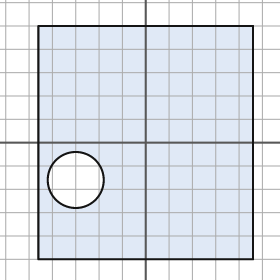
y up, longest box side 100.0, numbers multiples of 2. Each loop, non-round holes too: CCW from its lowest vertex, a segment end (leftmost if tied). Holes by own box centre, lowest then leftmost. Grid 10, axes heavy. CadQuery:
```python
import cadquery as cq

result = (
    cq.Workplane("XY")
    .moveTo(-46.0, -50.0)
    .lineTo(46.0, -50.0)
    .lineTo(46.0, 50.0)
    .lineTo(-46.0, 50.0)
    .close()
    .moveTo(-30.0, -16.0)
    .circle(12.0)
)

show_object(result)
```